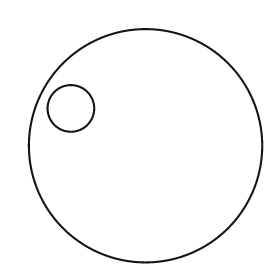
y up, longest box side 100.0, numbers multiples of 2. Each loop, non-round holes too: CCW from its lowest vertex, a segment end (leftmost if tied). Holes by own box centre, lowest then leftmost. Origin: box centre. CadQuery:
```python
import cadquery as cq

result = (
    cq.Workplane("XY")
    .moveTo(0.0, 0.0)
    .circle(50.0)
    .moveTo(-32.0, 16.0)
    .circle(10.0)
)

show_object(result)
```